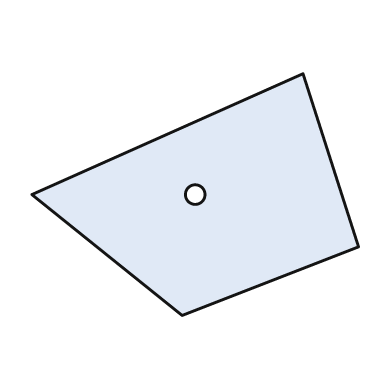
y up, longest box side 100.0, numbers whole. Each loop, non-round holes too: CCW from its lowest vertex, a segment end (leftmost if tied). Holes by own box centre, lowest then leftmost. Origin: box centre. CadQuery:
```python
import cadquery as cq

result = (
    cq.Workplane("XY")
    .moveTo(-4.0, -37.0)
    .lineTo(50.0, -16.0)
    .lineTo(33.0, 37.0)
    .lineTo(-50.0, 0.0)
    .close()
    .moveTo(0.0, 0.0)
    .circle(3.0)
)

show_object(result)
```